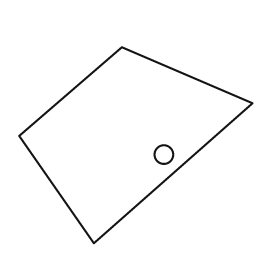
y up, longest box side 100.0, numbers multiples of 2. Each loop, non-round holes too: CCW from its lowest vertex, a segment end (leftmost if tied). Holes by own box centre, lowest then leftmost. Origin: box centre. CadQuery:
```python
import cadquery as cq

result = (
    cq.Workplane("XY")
    .moveTo(-18.0, -42.0)
    .lineTo(50.0, 18.0)
    .lineTo(-6.0, 42.0)
    .lineTo(-50.0, 4.0)
    .close()
    .moveTo(12.0, -4.0)
    .circle(4.0)
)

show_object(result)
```